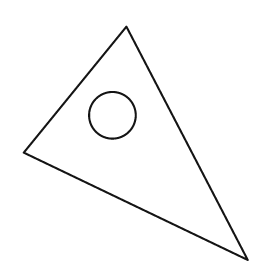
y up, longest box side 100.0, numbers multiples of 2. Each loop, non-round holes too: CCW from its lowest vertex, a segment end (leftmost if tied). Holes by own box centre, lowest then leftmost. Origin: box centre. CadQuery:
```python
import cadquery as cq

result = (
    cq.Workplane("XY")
    .moveTo(48.0, -50.0)
    .lineTo(-4.0, 50.0)
    .lineTo(-48.0, -4.0)
    .close()
    .moveTo(-10.0, 12.0)
    .circle(10.0)
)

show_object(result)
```